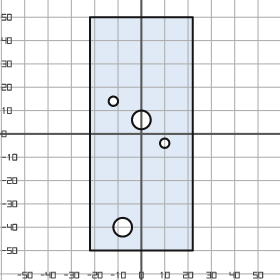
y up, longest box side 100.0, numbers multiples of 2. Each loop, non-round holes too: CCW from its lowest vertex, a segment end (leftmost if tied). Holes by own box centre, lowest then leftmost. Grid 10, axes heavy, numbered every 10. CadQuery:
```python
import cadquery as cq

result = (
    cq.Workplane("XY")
    .moveTo(-22.0, -50.0)
    .lineTo(22.0, -50.0)
    .lineTo(22.0, 50.0)
    .lineTo(-22.0, 50.0)
    .close()
    .moveTo(-8.0, -40.0)
    .circle(4.0)
    .moveTo(10.0, -4.0)
    .circle(2.0)
    .moveTo(0.0, 6.0)
    .circle(4.0)
    .moveTo(-12.0, 14.0)
    .circle(2.0)
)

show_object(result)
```